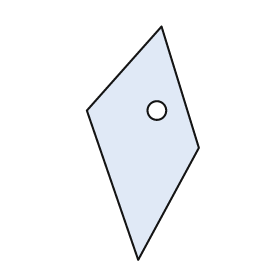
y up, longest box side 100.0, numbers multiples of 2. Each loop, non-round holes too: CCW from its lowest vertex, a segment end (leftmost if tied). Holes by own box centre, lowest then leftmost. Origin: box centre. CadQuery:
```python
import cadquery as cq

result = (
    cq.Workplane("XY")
    .moveTo(-2.0, -50.0)
    .lineTo(24.0, -2.0)
    .lineTo(8.0, 50.0)
    .lineTo(-24.0, 14.0)
    .close()
    .moveTo(6.0, 14.0)
    .circle(4.0)
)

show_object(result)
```